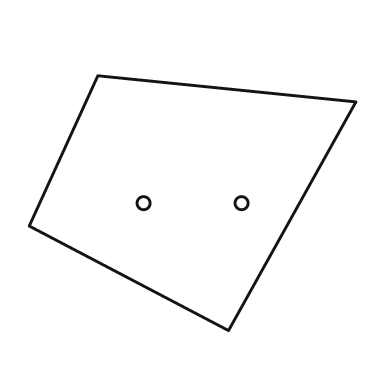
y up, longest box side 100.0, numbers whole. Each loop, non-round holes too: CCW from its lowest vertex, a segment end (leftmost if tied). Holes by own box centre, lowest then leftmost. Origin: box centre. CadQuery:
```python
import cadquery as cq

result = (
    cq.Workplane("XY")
    .moveTo(11.0, -39.0)
    .lineTo(50.0, 31.0)
    .lineTo(-29.0, 39.0)
    .lineTo(-50.0, -7.0)
    .close()
    .moveTo(-15.0, 0.0)
    .circle(2.0)
    .moveTo(15.0, 0.0)
    .circle(2.0)
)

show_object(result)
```